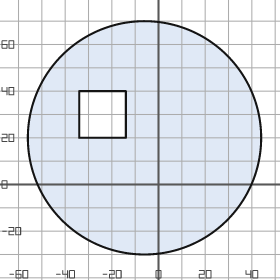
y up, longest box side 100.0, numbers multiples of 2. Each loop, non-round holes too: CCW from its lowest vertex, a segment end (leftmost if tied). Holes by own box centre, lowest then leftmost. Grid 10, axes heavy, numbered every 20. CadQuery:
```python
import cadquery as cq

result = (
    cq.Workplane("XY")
    .moveTo(-6.0, 20.0)
    .circle(50.0)
    .moveTo(-34.0, 20.0)
    .lineTo(-14.0, 20.0)
    .lineTo(-14.0, 40.0)
    .lineTo(-34.0, 40.0)
    .close()
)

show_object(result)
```